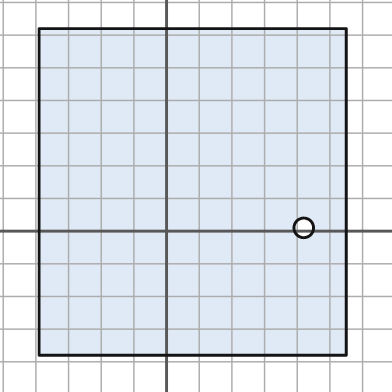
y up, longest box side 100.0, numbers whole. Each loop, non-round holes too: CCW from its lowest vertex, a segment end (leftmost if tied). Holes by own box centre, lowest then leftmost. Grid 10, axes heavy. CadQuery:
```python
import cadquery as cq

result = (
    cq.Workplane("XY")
    .moveTo(-39.0, -38.0)
    .lineTo(55.0, -38.0)
    .lineTo(55.0, 62.0)
    .lineTo(-39.0, 62.0)
    .close()
    .moveTo(42.0, 1.0)
    .circle(3.0)
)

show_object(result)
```